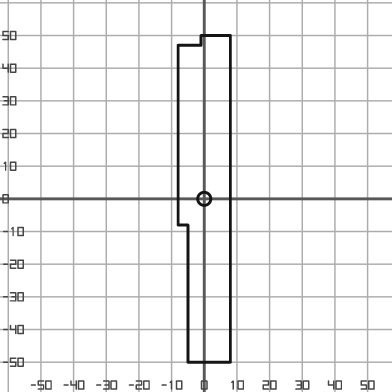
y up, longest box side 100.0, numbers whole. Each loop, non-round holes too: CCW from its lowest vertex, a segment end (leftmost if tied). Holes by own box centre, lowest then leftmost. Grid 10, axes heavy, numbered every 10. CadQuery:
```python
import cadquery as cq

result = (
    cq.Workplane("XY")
    .moveTo(-5.0, -50.0)
    .lineTo(8.0, -50.0)
    .lineTo(8.0, 50.0)
    .lineTo(-1.0, 50.0)
    .lineTo(-1.0, 47.0)
    .lineTo(-8.0, 47.0)
    .lineTo(-8.0, -8.0)
    .lineTo(-5.0, -8.0)
    .close()
    .moveTo(0.0, 0.0)
    .circle(2.0)
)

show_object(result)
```